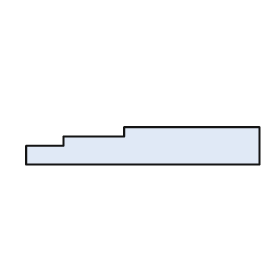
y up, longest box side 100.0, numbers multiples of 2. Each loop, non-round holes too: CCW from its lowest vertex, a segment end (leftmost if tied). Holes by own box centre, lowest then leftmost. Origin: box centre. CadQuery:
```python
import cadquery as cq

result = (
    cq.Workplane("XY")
    .moveTo(-50.0, -8.0)
    .lineTo(50.0, -8.0)
    .lineTo(50.0, 8.0)
    .lineTo(-8.0, 8.0)
    .lineTo(-8.0, 4.0)
    .lineTo(-34.0, 4.0)
    .lineTo(-34.0, 0.0)
    .lineTo(-50.0, 0.0)
    .close()
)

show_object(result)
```